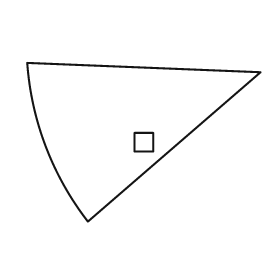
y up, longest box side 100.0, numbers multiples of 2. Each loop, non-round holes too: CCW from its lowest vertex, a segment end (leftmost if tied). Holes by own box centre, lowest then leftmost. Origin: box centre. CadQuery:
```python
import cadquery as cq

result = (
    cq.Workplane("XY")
    .moveTo(-24.0, -34.0)
    .lineTo(50.0, 30.0)
    .lineTo(-50.0, 34.0)
    .threePointArc((-42.0, -2.0), (-24.0, -34.0))
    .close()
    .moveTo(-4.0, -4.0)
    .lineTo(4.0, -4.0)
    .lineTo(4.0, 4.0)
    .lineTo(-4.0, 4.0)
    .close()
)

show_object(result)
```